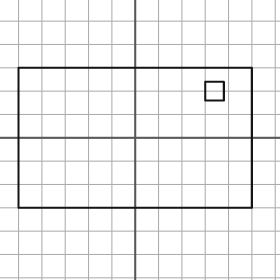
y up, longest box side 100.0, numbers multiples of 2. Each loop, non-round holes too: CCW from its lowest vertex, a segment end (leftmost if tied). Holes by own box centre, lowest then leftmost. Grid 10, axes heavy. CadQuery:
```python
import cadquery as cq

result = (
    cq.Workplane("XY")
    .moveTo(-50.0, -30.0)
    .lineTo(50.0, -30.0)
    .lineTo(50.0, 30.0)
    .lineTo(-50.0, 30.0)
    .close()
    .moveTo(30.0, 16.0)
    .lineTo(38.0, 16.0)
    .lineTo(38.0, 24.0)
    .lineTo(30.0, 24.0)
    .close()
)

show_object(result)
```